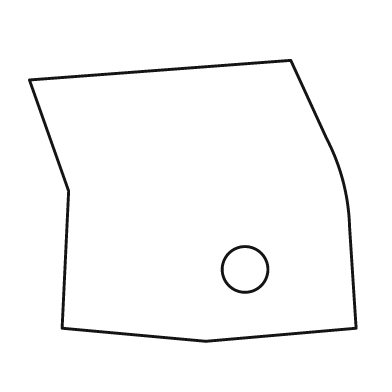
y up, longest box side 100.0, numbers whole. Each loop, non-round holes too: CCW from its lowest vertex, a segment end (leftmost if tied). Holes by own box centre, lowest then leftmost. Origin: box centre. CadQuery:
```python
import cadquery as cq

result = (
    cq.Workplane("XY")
    .moveTo(4.0, -43.0)
    .lineTo(50.0, -39.0)
    .lineTo(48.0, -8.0)
    .threePointArc((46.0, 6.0), (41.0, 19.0))
    .lineTo(30.0, 43.0)
    .lineTo(-50.0, 37.0)
    .lineTo(-38.0, 3.0)
    .lineTo(-40.0, -39.0)
    .close()
    .moveTo(16.0, -21.0)
    .circle(7.0)
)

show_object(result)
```